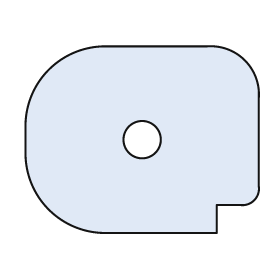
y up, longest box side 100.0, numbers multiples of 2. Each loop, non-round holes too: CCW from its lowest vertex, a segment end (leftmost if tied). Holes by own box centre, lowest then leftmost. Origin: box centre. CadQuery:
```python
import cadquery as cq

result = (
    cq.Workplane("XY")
    .moveTo(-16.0, -40.0)
    .lineTo(32.0, -40.0)
    .lineTo(32.0, -28.0)
    .lineTo(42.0, -28.0)
    .threePointArc((48.0, -26.0), (50.0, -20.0))
    .lineTo(50.0, 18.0)
    .threePointArc((44.0, 34.0), (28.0, 40.0))
    .lineTo(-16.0, 40.0)
    .threePointArc((-40.0, 30.0), (-50.0, 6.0))
    .lineTo(-50.0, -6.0)
    .threePointArc((-40.0, -30.0), (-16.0, -40.0))
    .close()
    .moveTo(0.0, 0.0)
    .circle(8.0)
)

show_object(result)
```